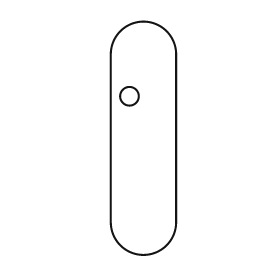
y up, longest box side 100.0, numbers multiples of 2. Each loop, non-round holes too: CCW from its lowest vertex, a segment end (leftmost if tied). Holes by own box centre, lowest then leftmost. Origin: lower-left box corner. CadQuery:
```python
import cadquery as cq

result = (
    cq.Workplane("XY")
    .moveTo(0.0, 14.0)
    .threePointArc((14.0, 0.0), (28.0, 14.0))
    .lineTo(28.0, 86.0)
    .threePointArc((14.0, 100.0), (0.0, 86.0))
    .close()
    .moveTo(8.0, 68.0)
    .circle(4.0)
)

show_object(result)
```